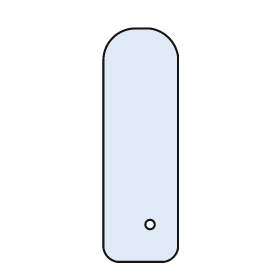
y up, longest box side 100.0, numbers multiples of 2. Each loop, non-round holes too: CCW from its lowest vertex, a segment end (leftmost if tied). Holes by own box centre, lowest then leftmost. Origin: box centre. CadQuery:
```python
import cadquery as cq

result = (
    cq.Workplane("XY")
    .moveTo(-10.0, -50.0)
    .lineTo(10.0, -50.0)
    .threePointArc((14.0, -48.0), (16.0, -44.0))
    .lineTo(16.0, 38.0)
    .threePointArc((12.0, 46.0), (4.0, 50.0))
    .lineTo(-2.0, 50.0)
    .threePointArc((-12.0, 46.0), (-16.0, 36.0))
    .lineTo(-16.0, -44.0)
    .threePointArc((-14.0, -48.0), (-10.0, -50.0))
    .close()
    .moveTo(4.0, -34.0)
    .circle(2.0)
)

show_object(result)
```